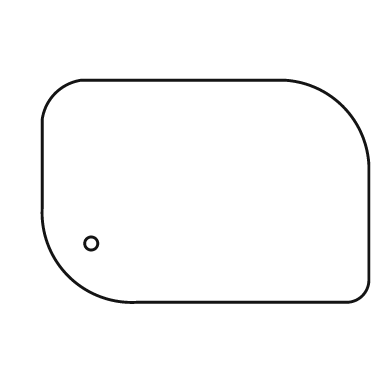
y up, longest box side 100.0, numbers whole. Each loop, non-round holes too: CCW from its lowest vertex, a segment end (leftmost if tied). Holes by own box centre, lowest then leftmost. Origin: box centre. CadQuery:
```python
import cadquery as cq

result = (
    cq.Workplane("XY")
    .moveTo(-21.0, -34.0)
    .lineTo(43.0, -34.0)
    .threePointArc((48.0, -32.0), (50.0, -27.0))
    .lineTo(50.0, 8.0)
    .threePointArc((42.0, 26.0), (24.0, 34.0))
    .lineTo(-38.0, 34.0)
    .threePointArc((-46.0, 30.0), (-50.0, 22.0))
    .lineTo(-50.0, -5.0)
    .threePointArc((-42.0, -26.0), (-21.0, -34.0))
    .close()
    .moveTo(-35.0, -16.0)
    .circle(2.0)
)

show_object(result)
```